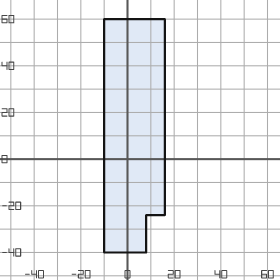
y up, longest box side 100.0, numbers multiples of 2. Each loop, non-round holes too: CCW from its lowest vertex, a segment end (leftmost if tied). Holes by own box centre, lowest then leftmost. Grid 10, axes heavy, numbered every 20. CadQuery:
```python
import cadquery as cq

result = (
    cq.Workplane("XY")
    .moveTo(-10.0, -40.0)
    .lineTo(8.0, -40.0)
    .lineTo(8.0, -24.0)
    .lineTo(16.0, -24.0)
    .lineTo(16.0, 60.0)
    .lineTo(-10.0, 60.0)
    .close()
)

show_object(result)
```